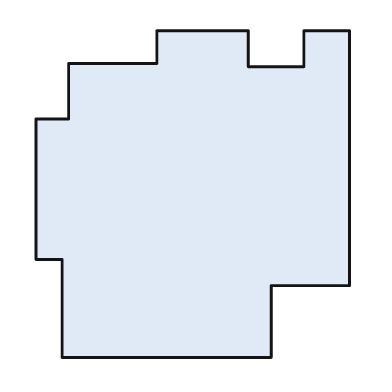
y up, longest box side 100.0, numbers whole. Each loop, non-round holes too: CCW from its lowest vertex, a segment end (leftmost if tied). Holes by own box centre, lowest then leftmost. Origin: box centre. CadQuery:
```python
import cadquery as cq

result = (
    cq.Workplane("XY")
    .moveTo(-40.0, -50.0)
    .lineTo(24.0, -50.0)
    .lineTo(24.0, -28.0)
    .lineTo(48.0, -28.0)
    .lineTo(48.0, 50.0)
    .lineTo(34.0, 50.0)
    .lineTo(34.0, 39.0)
    .lineTo(17.0, 39.0)
    .lineTo(17.0, 50.0)
    .lineTo(-11.0, 50.0)
    .lineTo(-11.0, 40.0)
    .lineTo(-38.0, 40.0)
    .lineTo(-38.0, 23.0)
    .lineTo(-48.0, 23.0)
    .lineTo(-48.0, -20.0)
    .lineTo(-40.0, -20.0)
    .close()
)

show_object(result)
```